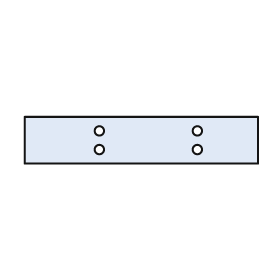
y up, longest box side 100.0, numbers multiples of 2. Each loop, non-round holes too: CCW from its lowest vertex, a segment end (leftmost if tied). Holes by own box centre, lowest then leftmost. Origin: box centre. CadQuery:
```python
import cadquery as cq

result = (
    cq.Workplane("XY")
    .moveTo(-50.0, -10.0)
    .lineTo(50.0, -10.0)
    .lineTo(50.0, 10.0)
    .lineTo(-50.0, 10.0)
    .close()
    .moveTo(-18.0, -4.0)
    .circle(2.0)
    .moveTo(24.0, -4.0)
    .circle(2.0)
    .moveTo(-18.0, 4.0)
    .circle(2.0)
    .moveTo(24.0, 4.0)
    .circle(2.0)
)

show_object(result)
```